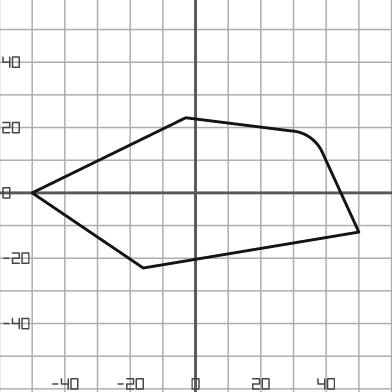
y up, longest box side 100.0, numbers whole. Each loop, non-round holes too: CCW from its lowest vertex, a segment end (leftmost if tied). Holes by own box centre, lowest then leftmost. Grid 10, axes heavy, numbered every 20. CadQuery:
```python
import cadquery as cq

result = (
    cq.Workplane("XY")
    .moveTo(-16.0, -23.0)
    .lineTo(50.0, -12.0)
    .lineTo(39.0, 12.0)
    .threePointArc((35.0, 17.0), (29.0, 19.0))
    .lineTo(-3.0, 23.0)
    .lineTo(-50.0, 0.0)
    .close()
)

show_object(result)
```